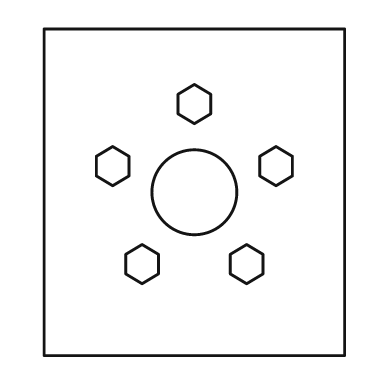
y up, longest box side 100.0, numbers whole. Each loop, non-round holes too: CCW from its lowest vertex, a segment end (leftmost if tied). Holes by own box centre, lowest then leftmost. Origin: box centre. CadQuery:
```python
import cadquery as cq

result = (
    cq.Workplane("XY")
    .moveTo(-46.0, -50.0)
    .lineTo(46.0, -50.0)
    .lineTo(46.0, 50.0)
    .lineTo(-46.0, 50.0)
    .close()
    .moveTo(-16.0, -28.0)
    .lineTo(-11.0, -25.0)
    .lineTo(-11.0, -19.0)
    .lineTo(-16.0, -16.0)
    .lineTo(-21.0, -19.0)
    .lineTo(-21.0, -25.0)
    .close()
    .moveTo(16.0, -28.0)
    .lineTo(21.0, -25.0)
    .lineTo(21.0, -19.0)
    .lineTo(16.0, -16.0)
    .lineTo(11.0, -19.0)
    .lineTo(11.0, -25.0)
    .close()
    .moveTo(0.0, 0.0)
    .circle(13.0)
    .moveTo(-25.0, 2.0)
    .lineTo(-20.0, 5.0)
    .lineTo(-20.0, 11.0)
    .lineTo(-25.0, 14.0)
    .lineTo(-30.0, 11.0)
    .lineTo(-30.0, 5.0)
    .close()
    .moveTo(25.0, 2.0)
    .lineTo(30.0, 5.0)
    .lineTo(30.0, 11.0)
    .lineTo(25.0, 14.0)
    .lineTo(20.0, 11.0)
    .lineTo(20.0, 5.0)
    .close()
    .moveTo(0.0, 21.0)
    .lineTo(5.0, 24.0)
    .lineTo(5.0, 30.0)
    .lineTo(0.0, 33.0)
    .lineTo(-5.0, 30.0)
    .lineTo(-5.0, 24.0)
    .close()
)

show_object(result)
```